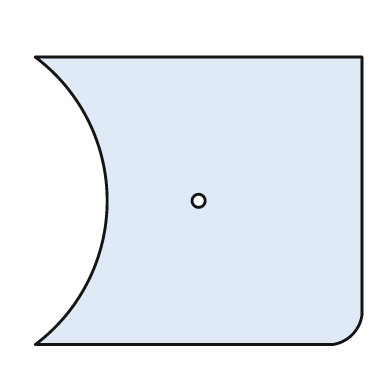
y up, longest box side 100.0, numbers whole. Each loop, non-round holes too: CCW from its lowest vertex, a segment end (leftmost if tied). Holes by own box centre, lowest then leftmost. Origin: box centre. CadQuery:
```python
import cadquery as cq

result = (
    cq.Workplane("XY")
    .moveTo(-50.0, -44.0)
    .lineTo(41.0, -44.0)
    .threePointArc((47.0, -41.0), (50.0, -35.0))
    .lineTo(50.0, 44.0)
    .lineTo(-50.0, 44.0)
    .threePointArc((-28.0, 0.0), (-50.0, -44.0))
    .close()
    .moveTo(0.0, 0.0)
    .circle(2.0)
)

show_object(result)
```